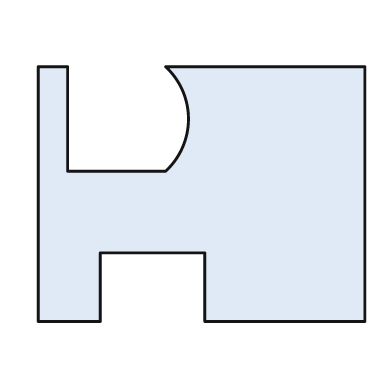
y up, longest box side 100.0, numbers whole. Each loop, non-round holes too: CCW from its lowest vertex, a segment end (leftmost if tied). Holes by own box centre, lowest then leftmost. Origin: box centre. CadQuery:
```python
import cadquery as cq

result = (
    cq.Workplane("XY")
    .moveTo(-50.0, -39.0)
    .lineTo(-31.0, -39.0)
    .lineTo(-31.0, -18.0)
    .lineTo(1.0, -18.0)
    .lineTo(1.0, -39.0)
    .lineTo(50.0, -39.0)
    .lineTo(50.0, 39.0)
    .lineTo(-11.0, 39.0)
    .threePointArc((-4.0, 23.0), (-11.0, 7.0))
    .lineTo(-41.0, 7.0)
    .lineTo(-41.0, 39.0)
    .lineTo(-50.0, 39.0)
    .close()
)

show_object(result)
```